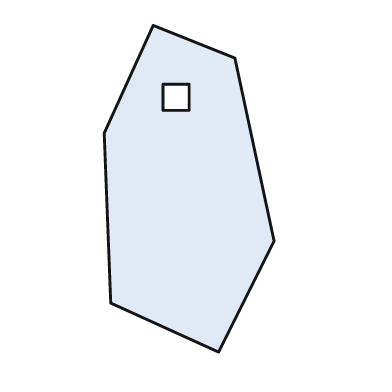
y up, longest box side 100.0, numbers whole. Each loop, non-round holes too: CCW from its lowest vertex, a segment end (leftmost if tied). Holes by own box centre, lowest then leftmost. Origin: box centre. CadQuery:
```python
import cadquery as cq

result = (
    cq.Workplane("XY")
    .moveTo(9.0, -50.0)
    .lineTo(26.0, -16.0)
    .lineTo(14.0, 40.0)
    .lineTo(-11.0, 50.0)
    .lineTo(-26.0, 17.0)
    .lineTo(-24.0, -35.0)
    .close()
    .moveTo(-8.0, 24.0)
    .lineTo(0.0, 24.0)
    .lineTo(0.0, 32.0)
    .lineTo(-8.0, 32.0)
    .close()
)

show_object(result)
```